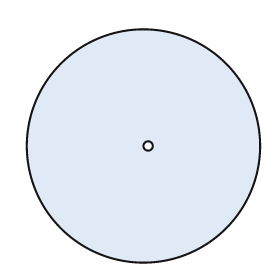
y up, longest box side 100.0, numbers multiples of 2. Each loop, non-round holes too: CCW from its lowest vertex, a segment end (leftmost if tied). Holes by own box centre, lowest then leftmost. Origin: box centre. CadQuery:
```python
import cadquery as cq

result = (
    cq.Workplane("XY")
    .moveTo(0.0, 0.0)
    .circle(50.0)
    .moveTo(2.0, 0.0)
    .circle(2.0)
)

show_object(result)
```